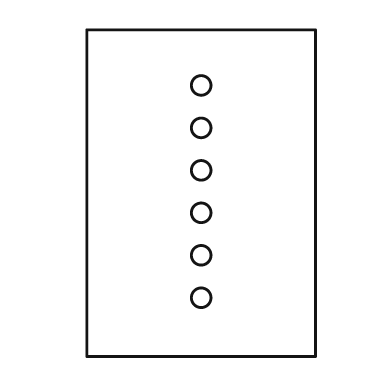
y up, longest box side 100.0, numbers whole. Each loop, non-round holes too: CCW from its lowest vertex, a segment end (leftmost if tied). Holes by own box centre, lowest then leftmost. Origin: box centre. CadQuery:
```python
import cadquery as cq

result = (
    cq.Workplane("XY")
    .moveTo(-35.0, -50.0)
    .lineTo(35.0, -50.0)
    .lineTo(35.0, 50.0)
    .lineTo(-35.0, 50.0)
    .close()
    .moveTo(0.0, -32.0)
    .circle(3.0)
    .moveTo(0.0, -19.0)
    .circle(3.0)
    .moveTo(0.0, -6.0)
    .circle(3.0)
    .moveTo(0.0, 7.0)
    .circle(3.0)
    .moveTo(0.0, 20.0)
    .circle(3.0)
    .moveTo(0.0, 33.0)
    .circle(3.0)
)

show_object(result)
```